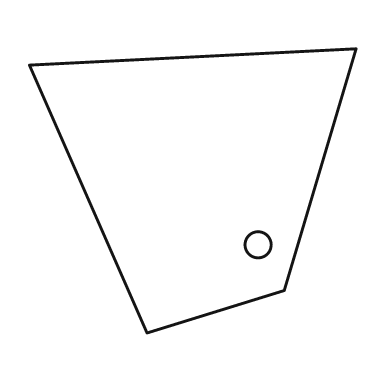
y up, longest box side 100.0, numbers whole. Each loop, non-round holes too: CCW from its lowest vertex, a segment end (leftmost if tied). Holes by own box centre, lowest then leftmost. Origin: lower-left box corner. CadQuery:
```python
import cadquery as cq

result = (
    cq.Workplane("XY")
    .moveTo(36.0, 0.0)
    .lineTo(78.0, 13.0)
    .lineTo(100.0, 87.0)
    .lineTo(0.0, 82.0)
    .close()
    .moveTo(70.0, 27.0)
    .circle(4.0)
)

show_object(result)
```